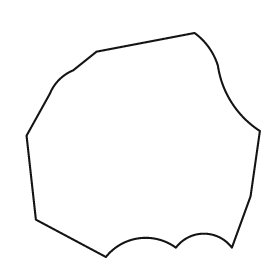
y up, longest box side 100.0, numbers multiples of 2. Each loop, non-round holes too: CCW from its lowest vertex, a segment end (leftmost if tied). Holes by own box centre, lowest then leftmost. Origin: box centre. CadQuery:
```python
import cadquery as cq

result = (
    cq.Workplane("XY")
    .moveTo(-16.0, -48.0)
    .threePointArc((-2.0, -40.0), (14.0, -44.0))
    .threePointArc((26.0, -38.0), (38.0, -44.0))
    .lineTo(46.0, -22.0)
    .lineTo(50.0, 6.0)
    .threePointArc((38.0, 18.0), (32.0, 34.0))
    .threePointArc((28.0, 42.0), (22.0, 48.0))
    .lineTo(-20.0, 40.0)
    .lineTo(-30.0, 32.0)
    .threePointArc((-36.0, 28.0), (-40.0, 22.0))
    .lineTo(-50.0, 4.0)
    .lineTo(-46.0, -32.0)
    .close()
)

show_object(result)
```